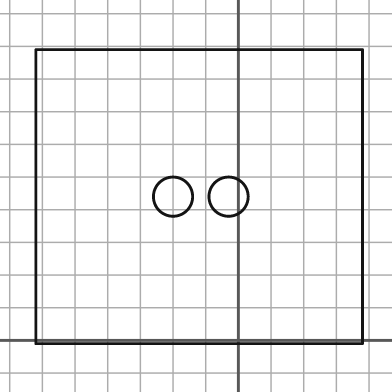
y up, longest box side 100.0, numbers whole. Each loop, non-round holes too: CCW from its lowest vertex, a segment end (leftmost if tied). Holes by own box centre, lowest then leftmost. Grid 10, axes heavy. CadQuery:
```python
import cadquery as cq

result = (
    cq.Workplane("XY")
    .moveTo(-62.0, -1.0)
    .lineTo(38.0, -1.0)
    .lineTo(38.0, 89.0)
    .lineTo(-62.0, 89.0)
    .close()
    .moveTo(-20.0, 44.0)
    .circle(6.0)
    .moveTo(-3.0, 44.0)
    .circle(6.0)
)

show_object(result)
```